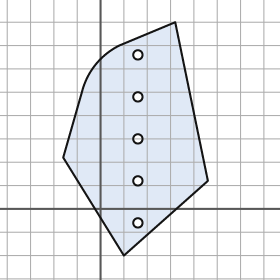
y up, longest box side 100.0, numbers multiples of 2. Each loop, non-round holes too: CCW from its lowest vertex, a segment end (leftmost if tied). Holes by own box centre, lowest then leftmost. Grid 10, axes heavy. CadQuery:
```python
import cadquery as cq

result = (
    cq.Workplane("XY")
    .moveTo(10.0, -20.0)
    .lineTo(46.0, 12.0)
    .lineTo(32.0, 80.0)
    .lineTo(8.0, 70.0)
    .threePointArc((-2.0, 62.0), (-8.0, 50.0))
    .lineTo(-16.0, 22.0)
    .close()
    .moveTo(16.0, -6.0)
    .circle(2.0)
    .moveTo(16.0, 12.0)
    .circle(2.0)
    .moveTo(16.0, 30.0)
    .circle(2.0)
    .moveTo(16.0, 48.0)
    .circle(2.0)
    .moveTo(16.0, 66.0)
    .circle(2.0)
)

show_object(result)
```